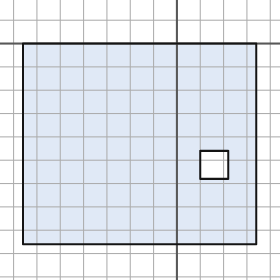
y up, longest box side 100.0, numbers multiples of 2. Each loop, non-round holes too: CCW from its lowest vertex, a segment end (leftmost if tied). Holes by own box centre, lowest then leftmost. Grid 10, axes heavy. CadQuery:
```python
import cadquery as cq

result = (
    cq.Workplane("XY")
    .moveTo(-66.0, -86.0)
    .lineTo(34.0, -86.0)
    .lineTo(34.0, 0.0)
    .lineTo(-66.0, 0.0)
    .close()
    .moveTo(10.0, -58.0)
    .lineTo(22.0, -58.0)
    .lineTo(22.0, -46.0)
    .lineTo(10.0, -46.0)
    .close()
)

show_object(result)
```